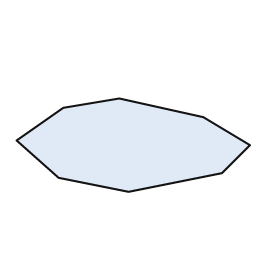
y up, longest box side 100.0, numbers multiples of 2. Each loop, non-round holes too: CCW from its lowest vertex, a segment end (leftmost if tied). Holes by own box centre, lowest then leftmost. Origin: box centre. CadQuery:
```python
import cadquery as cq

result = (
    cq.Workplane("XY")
    .moveTo(-2.0, -20.0)
    .lineTo(38.0, -12.0)
    .lineTo(50.0, 0.0)
    .lineTo(30.0, 12.0)
    .lineTo(-6.0, 20.0)
    .lineTo(-30.0, 16.0)
    .lineTo(-50.0, 2.0)
    .lineTo(-32.0, -14.0)
    .close()
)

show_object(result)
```